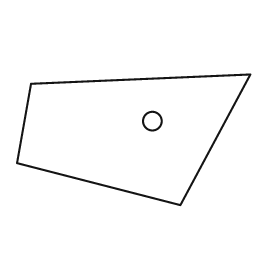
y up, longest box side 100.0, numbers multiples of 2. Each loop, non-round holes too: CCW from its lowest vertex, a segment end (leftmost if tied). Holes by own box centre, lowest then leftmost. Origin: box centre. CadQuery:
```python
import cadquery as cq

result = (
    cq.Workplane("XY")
    .moveTo(20.0, -28.0)
    .lineTo(50.0, 28.0)
    .lineTo(-44.0, 24.0)
    .lineTo(-50.0, -10.0)
    .close()
    .moveTo(8.0, 8.0)
    .circle(4.0)
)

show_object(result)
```